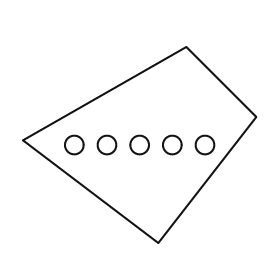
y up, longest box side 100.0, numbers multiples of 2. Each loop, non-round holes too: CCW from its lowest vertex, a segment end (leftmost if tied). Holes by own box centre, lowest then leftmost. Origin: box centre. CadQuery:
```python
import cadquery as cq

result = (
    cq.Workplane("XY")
    .moveTo(8.0, -42.0)
    .lineTo(50.0, 12.0)
    .lineTo(20.0, 42.0)
    .lineTo(-50.0, 2.0)
    .close()
    .moveTo(-28.0, 0.0)
    .circle(4.0)
    .moveTo(-14.0, 0.0)
    .circle(4.0)
    .moveTo(0.0, 0.0)
    .circle(4.0)
    .moveTo(14.0, 0.0)
    .circle(4.0)
    .moveTo(28.0, 0.0)
    .circle(4.0)
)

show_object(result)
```